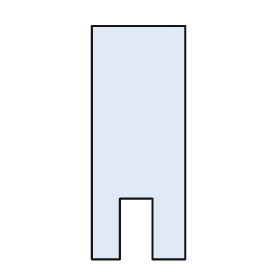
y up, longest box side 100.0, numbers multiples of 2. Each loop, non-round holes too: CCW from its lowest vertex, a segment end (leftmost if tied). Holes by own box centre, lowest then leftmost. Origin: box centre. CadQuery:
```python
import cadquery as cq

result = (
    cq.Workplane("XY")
    .moveTo(-20.0, -50.0)
    .lineTo(-8.0, -50.0)
    .lineTo(-8.0, -24.0)
    .lineTo(6.0, -24.0)
    .lineTo(6.0, -50.0)
    .lineTo(20.0, -50.0)
    .lineTo(20.0, 50.0)
    .lineTo(-20.0, 50.0)
    .close()
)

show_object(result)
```